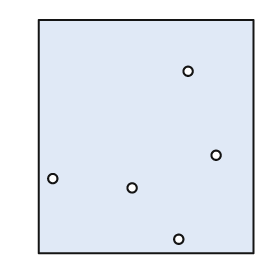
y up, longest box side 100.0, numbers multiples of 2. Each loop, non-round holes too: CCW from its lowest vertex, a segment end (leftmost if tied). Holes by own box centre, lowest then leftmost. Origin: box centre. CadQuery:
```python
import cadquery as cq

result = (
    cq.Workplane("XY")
    .moveTo(-46.0, -50.0)
    .lineTo(46.0, -50.0)
    .lineTo(46.0, 50.0)
    .lineTo(-46.0, 50.0)
    .close()
    .moveTo(14.0, -44.0)
    .circle(2.0)
    .moveTo(-6.0, -22.0)
    .circle(2.0)
    .moveTo(-40.0, -18.0)
    .circle(2.0)
    .moveTo(30.0, -8.0)
    .circle(2.0)
    .moveTo(18.0, 28.0)
    .circle(2.0)
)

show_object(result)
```